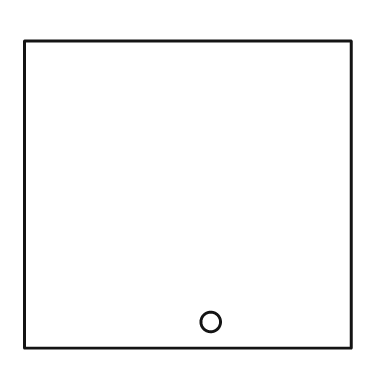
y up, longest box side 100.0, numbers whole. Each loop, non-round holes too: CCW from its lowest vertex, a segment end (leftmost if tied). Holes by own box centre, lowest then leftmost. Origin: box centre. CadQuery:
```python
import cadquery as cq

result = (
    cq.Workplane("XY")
    .moveTo(-50.0, -47.0)
    .lineTo(50.0, -47.0)
    .lineTo(50.0, 47.0)
    .lineTo(-50.0, 47.0)
    .close()
    .moveTo(7.0, -39.0)
    .circle(3.0)
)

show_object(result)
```